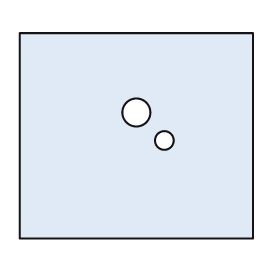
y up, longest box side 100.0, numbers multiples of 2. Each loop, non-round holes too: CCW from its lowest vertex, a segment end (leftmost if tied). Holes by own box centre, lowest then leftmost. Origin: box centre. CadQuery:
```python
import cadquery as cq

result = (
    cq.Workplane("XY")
    .moveTo(-50.0, -44.0)
    .lineTo(50.0, -44.0)
    .lineTo(50.0, 44.0)
    .lineTo(-50.0, 44.0)
    .close()
    .moveTo(12.0, -2.0)
    .circle(4.0)
    .moveTo(0.0, 10.0)
    .circle(6.0)
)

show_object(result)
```